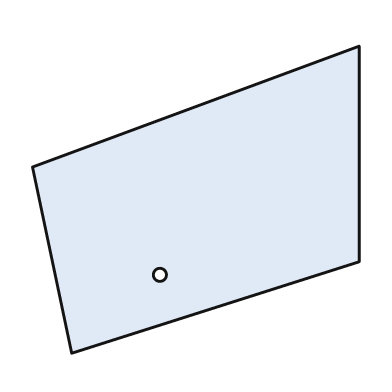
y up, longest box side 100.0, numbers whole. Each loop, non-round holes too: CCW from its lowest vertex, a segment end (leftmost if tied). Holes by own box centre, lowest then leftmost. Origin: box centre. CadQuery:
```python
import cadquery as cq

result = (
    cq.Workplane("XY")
    .moveTo(-38.0, -47.0)
    .lineTo(50.0, -19.0)
    .lineTo(50.0, 47.0)
    .lineTo(-50.0, 10.0)
    .close()
    .moveTo(-11.0, -23.0)
    .circle(2.0)
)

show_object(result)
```